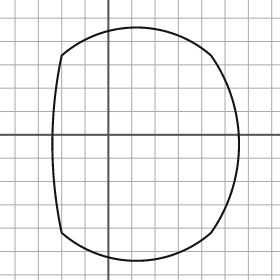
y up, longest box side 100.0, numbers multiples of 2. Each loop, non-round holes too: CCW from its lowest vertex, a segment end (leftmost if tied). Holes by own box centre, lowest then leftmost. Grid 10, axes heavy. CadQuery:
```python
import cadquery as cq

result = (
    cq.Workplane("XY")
    .moveTo(-20.0, -42.0)
    .threePointArc((12.0, -54.0), (44.0, -42.0))
    .threePointArc((56.0, -4.0), (44.0, 34.0))
    .threePointArc((12.0, 46.0), (-20.0, 34.0))
    .threePointArc((-24.0, -4.0), (-20.0, -42.0))
    .close()
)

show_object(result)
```